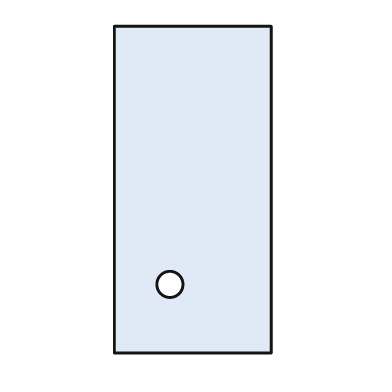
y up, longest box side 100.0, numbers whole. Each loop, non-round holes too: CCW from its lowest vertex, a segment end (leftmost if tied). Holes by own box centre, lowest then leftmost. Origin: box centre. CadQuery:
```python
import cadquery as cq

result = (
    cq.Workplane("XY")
    .moveTo(-24.0, -50.0)
    .lineTo(24.0, -50.0)
    .lineTo(24.0, 50.0)
    .lineTo(-24.0, 50.0)
    .close()
    .moveTo(-7.0, -29.0)
    .circle(4.0)
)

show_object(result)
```